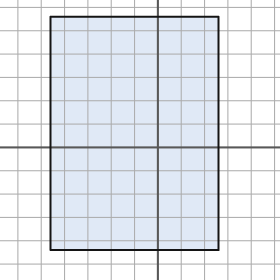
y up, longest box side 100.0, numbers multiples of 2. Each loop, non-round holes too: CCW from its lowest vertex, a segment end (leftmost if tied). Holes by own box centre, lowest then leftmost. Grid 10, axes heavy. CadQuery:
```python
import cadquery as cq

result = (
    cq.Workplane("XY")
    .moveTo(-46.0, -44.0)
    .lineTo(26.0, -44.0)
    .lineTo(26.0, 56.0)
    .lineTo(-46.0, 56.0)
    .close()
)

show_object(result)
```